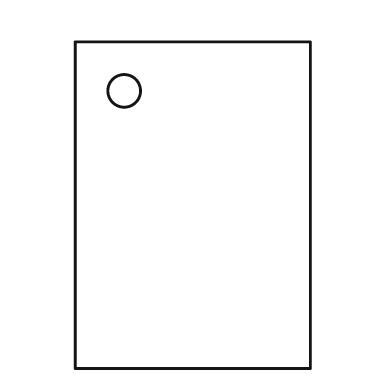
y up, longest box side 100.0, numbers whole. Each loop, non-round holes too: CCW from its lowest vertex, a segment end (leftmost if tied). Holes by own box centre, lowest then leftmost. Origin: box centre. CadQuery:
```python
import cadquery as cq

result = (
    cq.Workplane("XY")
    .moveTo(-36.0, -50.0)
    .lineTo(36.0, -50.0)
    .lineTo(36.0, 50.0)
    .lineTo(-36.0, 50.0)
    .close()
    .moveTo(-21.0, 35.0)
    .circle(5.0)
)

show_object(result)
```